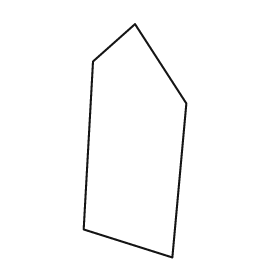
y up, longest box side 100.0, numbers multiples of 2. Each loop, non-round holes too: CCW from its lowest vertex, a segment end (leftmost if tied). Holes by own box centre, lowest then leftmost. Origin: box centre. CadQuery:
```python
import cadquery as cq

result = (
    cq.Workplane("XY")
    .moveTo(16.0, -50.0)
    .lineTo(22.0, 16.0)
    .lineTo(0.0, 50.0)
    .lineTo(-18.0, 34.0)
    .lineTo(-22.0, -38.0)
    .close()
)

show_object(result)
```